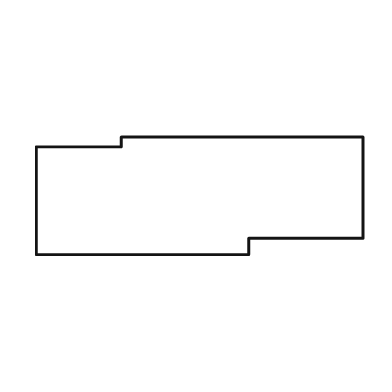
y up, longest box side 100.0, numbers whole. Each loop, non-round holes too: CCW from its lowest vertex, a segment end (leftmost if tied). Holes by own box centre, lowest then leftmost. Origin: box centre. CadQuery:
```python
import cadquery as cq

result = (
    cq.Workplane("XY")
    .moveTo(-50.0, -18.0)
    .lineTo(15.0, -18.0)
    .lineTo(15.0, -13.0)
    .lineTo(50.0, -13.0)
    .lineTo(50.0, 18.0)
    .lineTo(-24.0, 18.0)
    .lineTo(-24.0, 15.0)
    .lineTo(-50.0, 15.0)
    .close()
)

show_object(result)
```